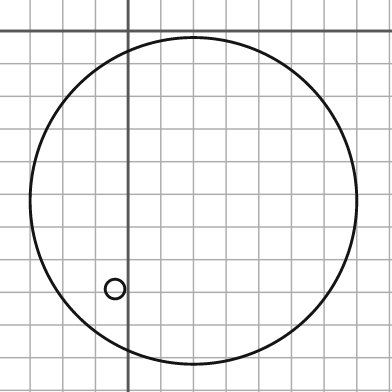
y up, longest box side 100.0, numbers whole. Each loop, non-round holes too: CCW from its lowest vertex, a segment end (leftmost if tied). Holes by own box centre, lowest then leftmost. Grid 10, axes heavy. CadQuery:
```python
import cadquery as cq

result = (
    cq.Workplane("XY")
    .moveTo(20.0, -52.0)
    .circle(50.0)
    .moveTo(-4.0, -79.0)
    .circle(3.0)
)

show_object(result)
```